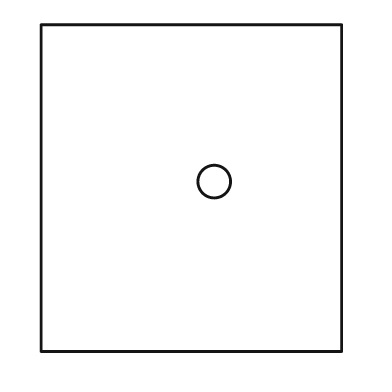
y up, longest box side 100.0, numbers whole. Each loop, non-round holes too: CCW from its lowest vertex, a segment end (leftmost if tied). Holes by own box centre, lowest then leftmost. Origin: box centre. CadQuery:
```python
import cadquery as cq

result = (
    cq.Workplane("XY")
    .moveTo(-46.0, -50.0)
    .lineTo(46.0, -50.0)
    .lineTo(46.0, 50.0)
    .lineTo(-46.0, 50.0)
    .close()
    .moveTo(7.0, 2.0)
    .circle(5.0)
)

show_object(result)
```